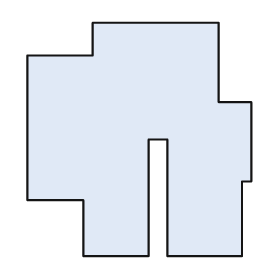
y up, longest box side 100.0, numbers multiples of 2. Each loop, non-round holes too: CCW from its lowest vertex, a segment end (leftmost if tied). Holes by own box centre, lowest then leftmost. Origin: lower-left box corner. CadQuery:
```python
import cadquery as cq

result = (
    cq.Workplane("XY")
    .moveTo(24.0, 0.0)
    .lineTo(52.0, 0.0)
    .lineTo(52.0, 50.0)
    .lineTo(60.0, 50.0)
    .lineTo(60.0, 0.0)
    .lineTo(92.0, 0.0)
    .lineTo(92.0, 32.0)
    .lineTo(96.0, 32.0)
    .lineTo(96.0, 66.0)
    .lineTo(82.0, 66.0)
    .lineTo(82.0, 100.0)
    .lineTo(28.0, 100.0)
    .lineTo(28.0, 86.0)
    .lineTo(0.0, 86.0)
    .lineTo(0.0, 24.0)
    .lineTo(24.0, 24.0)
    .close()
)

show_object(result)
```